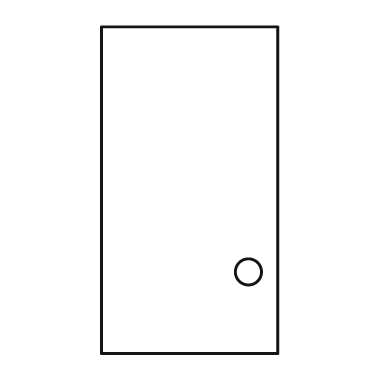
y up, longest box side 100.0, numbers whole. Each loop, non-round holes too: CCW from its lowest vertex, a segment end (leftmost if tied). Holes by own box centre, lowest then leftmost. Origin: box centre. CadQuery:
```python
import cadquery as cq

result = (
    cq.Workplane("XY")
    .moveTo(-27.0, -50.0)
    .lineTo(27.0, -50.0)
    .lineTo(27.0, 50.0)
    .lineTo(-27.0, 50.0)
    .close()
    .moveTo(18.0, -25.0)
    .circle(4.0)
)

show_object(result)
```